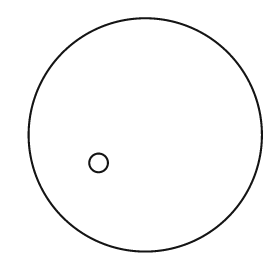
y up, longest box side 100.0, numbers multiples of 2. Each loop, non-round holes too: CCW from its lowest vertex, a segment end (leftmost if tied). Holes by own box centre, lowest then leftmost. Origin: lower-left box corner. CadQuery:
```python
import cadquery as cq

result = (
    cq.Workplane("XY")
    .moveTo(50.0, 50.0)
    .circle(50.0)
    .moveTo(30.0, 38.0)
    .circle(4.0)
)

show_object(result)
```